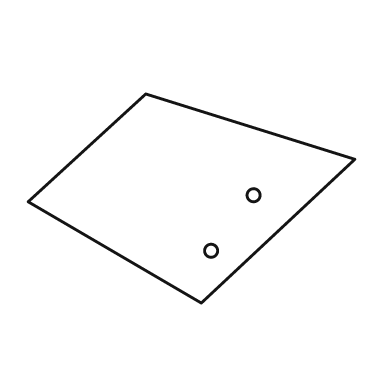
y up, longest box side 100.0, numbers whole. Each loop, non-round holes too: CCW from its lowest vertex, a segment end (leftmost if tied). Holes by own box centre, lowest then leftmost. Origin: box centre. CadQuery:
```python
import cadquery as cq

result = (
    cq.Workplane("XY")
    .moveTo(3.0, -32.0)
    .lineTo(50.0, 12.0)
    .lineTo(-14.0, 32.0)
    .lineTo(-50.0, -1.0)
    .close()
    .moveTo(6.0, -16.0)
    .circle(2.0)
    .moveTo(19.0, 1.0)
    .circle(2.0)
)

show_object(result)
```